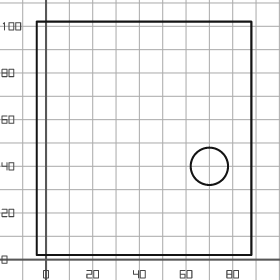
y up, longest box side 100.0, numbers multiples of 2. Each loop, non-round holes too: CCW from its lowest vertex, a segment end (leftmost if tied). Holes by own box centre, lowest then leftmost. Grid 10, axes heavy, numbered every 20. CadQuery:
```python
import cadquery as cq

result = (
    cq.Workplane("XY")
    .moveTo(-4.0, 2.0)
    .lineTo(88.0, 2.0)
    .lineTo(88.0, 102.0)
    .lineTo(-4.0, 102.0)
    .close()
    .moveTo(70.0, 40.0)
    .circle(8.0)
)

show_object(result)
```